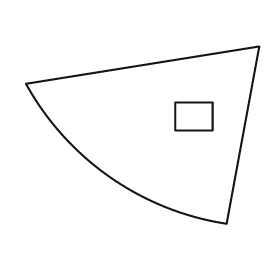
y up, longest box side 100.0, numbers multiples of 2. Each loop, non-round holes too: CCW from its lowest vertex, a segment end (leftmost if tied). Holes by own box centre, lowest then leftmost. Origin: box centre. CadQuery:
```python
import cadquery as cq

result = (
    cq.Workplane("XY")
    .moveTo(36.0, -38.0)
    .lineTo(50.0, 38.0)
    .lineTo(-50.0, 22.0)
    .threePointArc((-14.0, -18.0), (36.0, -38.0))
    .close()
    .moveTo(14.0, 2.0)
    .lineTo(30.0, 2.0)
    .lineTo(30.0, 14.0)
    .lineTo(14.0, 14.0)
    .close()
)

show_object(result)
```